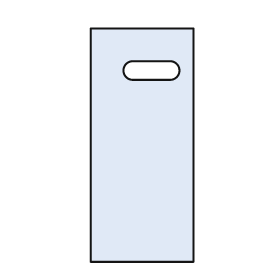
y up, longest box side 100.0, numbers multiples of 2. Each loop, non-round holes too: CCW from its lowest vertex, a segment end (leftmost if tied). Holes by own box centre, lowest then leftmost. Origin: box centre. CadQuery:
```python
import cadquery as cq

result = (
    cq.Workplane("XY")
    .moveTo(-22.0, -50.0)
    .lineTo(22.0, -50.0)
    .lineTo(22.0, 50.0)
    .lineTo(-22.0, 50.0)
    .close()
    .moveTo(-4.0, 28.0)
    .lineTo(12.0, 28.0)
    .threePointArc((16.0, 32.0), (12.0, 36.0))
    .lineTo(-4.0, 36.0)
    .threePointArc((-8.0, 32.0), (-4.0, 28.0))
    .close()
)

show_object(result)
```